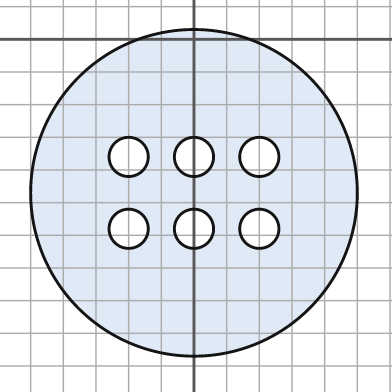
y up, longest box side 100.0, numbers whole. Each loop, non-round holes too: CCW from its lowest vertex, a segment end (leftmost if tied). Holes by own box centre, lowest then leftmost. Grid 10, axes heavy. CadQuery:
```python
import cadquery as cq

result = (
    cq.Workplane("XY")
    .moveTo(0.0, -47.0)
    .circle(50.0)
    .moveTo(-20.0, -58.0)
    .circle(6.0)
    .moveTo(0.0, -58.0)
    .circle(6.0)
    .moveTo(20.0, -58.0)
    .circle(6.0)
    .moveTo(-20.0, -36.0)
    .circle(6.0)
    .moveTo(0.0, -36.0)
    .circle(6.0)
    .moveTo(20.0, -36.0)
    .circle(6.0)
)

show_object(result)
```